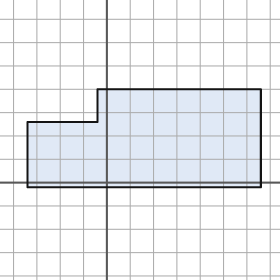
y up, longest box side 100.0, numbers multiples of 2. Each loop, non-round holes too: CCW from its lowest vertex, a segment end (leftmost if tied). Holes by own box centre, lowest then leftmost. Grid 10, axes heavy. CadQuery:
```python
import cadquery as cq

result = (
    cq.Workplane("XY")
    .moveTo(-34.0, -2.0)
    .lineTo(66.0, -2.0)
    .lineTo(66.0, 40.0)
    .lineTo(-4.0, 40.0)
    .lineTo(-4.0, 26.0)
    .lineTo(-34.0, 26.0)
    .close()
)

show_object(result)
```